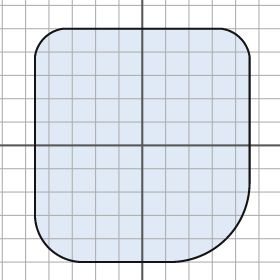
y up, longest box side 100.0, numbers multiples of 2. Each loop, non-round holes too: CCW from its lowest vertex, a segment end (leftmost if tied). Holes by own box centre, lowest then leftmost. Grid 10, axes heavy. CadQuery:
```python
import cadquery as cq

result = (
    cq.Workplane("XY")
    .moveTo(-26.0, -50.0)
    .lineTo(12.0, -50.0)
    .threePointArc((36.0, -40.0), (46.0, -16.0))
    .lineTo(46.0, 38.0)
    .threePointArc((42.0, 46.0), (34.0, 50.0))
    .lineTo(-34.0, 50.0)
    .threePointArc((-42.0, 46.0), (-46.0, 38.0))
    .lineTo(-46.0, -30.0)
    .threePointArc((-40.0, -44.0), (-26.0, -50.0))
    .close()
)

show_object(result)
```